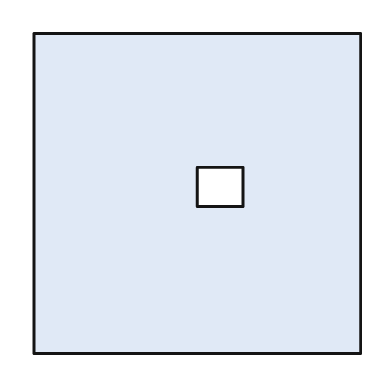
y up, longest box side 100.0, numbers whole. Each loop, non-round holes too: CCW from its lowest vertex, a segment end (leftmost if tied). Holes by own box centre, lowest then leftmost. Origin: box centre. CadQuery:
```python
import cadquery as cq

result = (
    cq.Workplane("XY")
    .moveTo(-50.0, -49.0)
    .lineTo(50.0, -49.0)
    .lineTo(50.0, 49.0)
    .lineTo(-50.0, 49.0)
    .close()
    .moveTo(0.0, -4.0)
    .lineTo(14.0, -4.0)
    .lineTo(14.0, 8.0)
    .lineTo(0.0, 8.0)
    .close()
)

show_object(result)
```